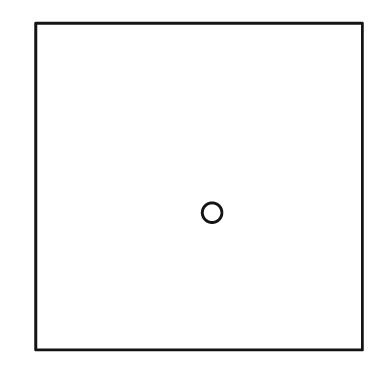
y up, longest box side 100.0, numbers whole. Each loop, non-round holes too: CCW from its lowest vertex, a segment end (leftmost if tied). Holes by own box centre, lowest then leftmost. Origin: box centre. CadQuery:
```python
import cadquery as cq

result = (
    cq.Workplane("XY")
    .moveTo(-50.0, -50.0)
    .lineTo(50.0, -50.0)
    .lineTo(50.0, 50.0)
    .lineTo(-50.0, 50.0)
    .close()
    .moveTo(4.0, -8.0)
    .circle(3.0)
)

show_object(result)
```